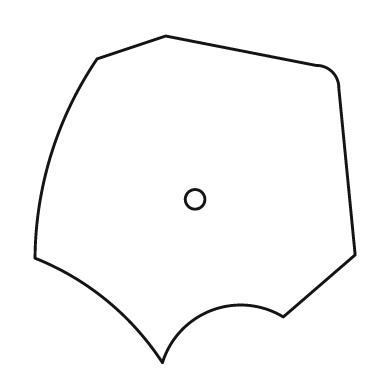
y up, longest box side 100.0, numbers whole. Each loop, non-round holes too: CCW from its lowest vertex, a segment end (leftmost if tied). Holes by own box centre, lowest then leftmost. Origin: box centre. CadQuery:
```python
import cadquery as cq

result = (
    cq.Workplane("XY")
    .moveTo(-10.0, -50.0)
    .threePointArc((5.0, -34.0), (27.0, -36.0))
    .lineTo(49.0, -17.0)
    .lineTo(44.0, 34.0)
    .threePointArc((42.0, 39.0), (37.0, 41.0))
    .lineTo(-9.0, 50.0)
    .lineTo(-30.0, 43.0)
    .threePointArc((-44.0, 14.0), (-49.0, -18.0))
    .threePointArc((-27.0, -31.0), (-10.0, -50.0))
    .close()
    .moveTo(0.0, 0.0)
    .circle(3.0)
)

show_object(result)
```